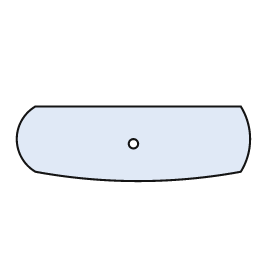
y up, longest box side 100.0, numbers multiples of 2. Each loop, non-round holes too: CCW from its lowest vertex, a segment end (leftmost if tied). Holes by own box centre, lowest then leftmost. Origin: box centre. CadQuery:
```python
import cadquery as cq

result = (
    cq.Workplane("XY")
    .moveTo(-42.0, -12.0)
    .threePointArc((2.0, -16.0), (46.0, -12.0))
    .threePointArc((50.0, 2.0), (46.0, 16.0))
    .lineTo(-42.0, 16.0)
    .threePointArc((-50.0, 2.0), (-42.0, -12.0))
    .close()
    .moveTo(0.0, 0.0)
    .circle(2.0)
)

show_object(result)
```